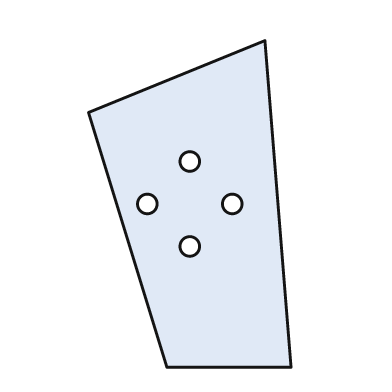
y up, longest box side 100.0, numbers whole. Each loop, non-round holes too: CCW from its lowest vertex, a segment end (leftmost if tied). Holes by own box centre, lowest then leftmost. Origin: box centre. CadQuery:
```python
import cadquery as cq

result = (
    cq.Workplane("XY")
    .moveTo(-7.0, -50.0)
    .lineTo(31.0, -50.0)
    .lineTo(23.0, 50.0)
    .lineTo(-31.0, 28.0)
    .close()
    .moveTo(0.0, -13.0)
    .circle(3.0)
    .moveTo(-13.0, 0.0)
    .circle(3.0)
    .moveTo(13.0, 0.0)
    .circle(3.0)
    .moveTo(0.0, 13.0)
    .circle(3.0)
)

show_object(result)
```